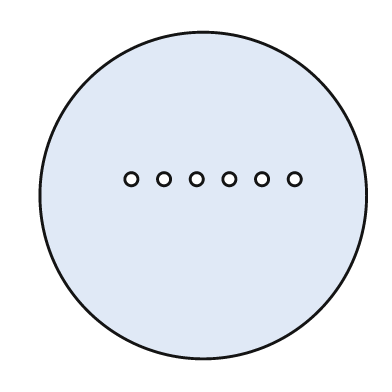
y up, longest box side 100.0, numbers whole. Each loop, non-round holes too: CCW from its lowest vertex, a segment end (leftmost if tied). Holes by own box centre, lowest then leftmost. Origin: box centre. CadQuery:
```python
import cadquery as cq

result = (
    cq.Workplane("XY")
    .moveTo(0.0, 0.0)
    .circle(50.0)
    .moveTo(-22.0, 5.0)
    .circle(2.0)
    .moveTo(-12.0, 5.0)
    .circle(2.0)
    .moveTo(-2.0, 5.0)
    .circle(2.0)
    .moveTo(8.0, 5.0)
    .circle(2.0)
    .moveTo(18.0, 5.0)
    .circle(2.0)
    .moveTo(28.0, 5.0)
    .circle(2.0)
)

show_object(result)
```